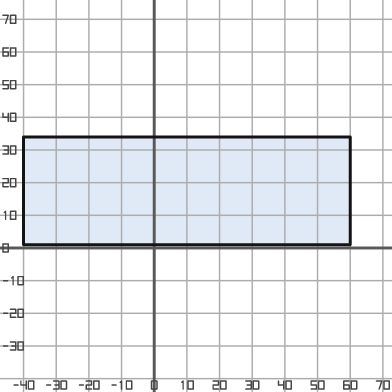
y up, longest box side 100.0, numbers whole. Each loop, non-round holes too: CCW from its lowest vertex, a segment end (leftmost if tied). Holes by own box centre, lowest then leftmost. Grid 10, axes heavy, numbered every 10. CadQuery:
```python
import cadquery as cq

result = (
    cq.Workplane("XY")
    .moveTo(-40.0, 1.0)
    .lineTo(60.0, 1.0)
    .lineTo(60.0, 34.0)
    .lineTo(-40.0, 34.0)
    .close()
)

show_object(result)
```